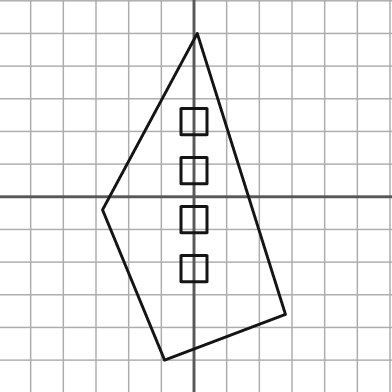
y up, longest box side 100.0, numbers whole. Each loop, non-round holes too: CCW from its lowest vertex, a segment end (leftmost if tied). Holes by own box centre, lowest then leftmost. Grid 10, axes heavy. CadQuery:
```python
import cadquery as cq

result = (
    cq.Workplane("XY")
    .moveTo(-9.0, -50.0)
    .lineTo(28.0, -36.0)
    .lineTo(1.0, 50.0)
    .lineTo(-28.0, -4.0)
    .close()
    .moveTo(-4.0, -26.0)
    .lineTo(4.0, -26.0)
    .lineTo(4.0, -18.0)
    .lineTo(-4.0, -18.0)
    .close()
    .moveTo(-4.0, -11.0)
    .lineTo(4.0, -11.0)
    .lineTo(4.0, -3.0)
    .lineTo(-4.0, -3.0)
    .close()
    .moveTo(-4.0, 4.0)
    .lineTo(4.0, 4.0)
    .lineTo(4.0, 12.0)
    .lineTo(-4.0, 12.0)
    .close()
    .moveTo(-4.0, 19.0)
    .lineTo(4.0, 19.0)
    .lineTo(4.0, 27.0)
    .lineTo(-4.0, 27.0)
    .close()
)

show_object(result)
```